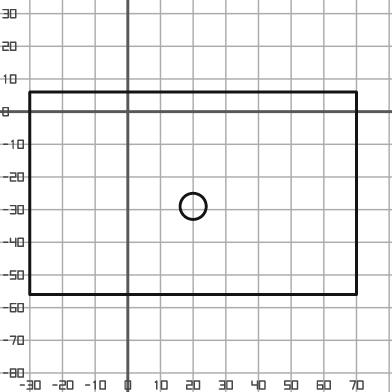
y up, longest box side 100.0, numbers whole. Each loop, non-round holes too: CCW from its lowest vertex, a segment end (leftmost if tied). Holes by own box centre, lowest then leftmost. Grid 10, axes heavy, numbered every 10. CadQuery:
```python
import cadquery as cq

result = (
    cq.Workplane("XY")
    .moveTo(-30.0, -56.0)
    .lineTo(70.0, -56.0)
    .lineTo(70.0, 6.0)
    .lineTo(-30.0, 6.0)
    .close()
    .moveTo(20.0, -29.0)
    .circle(4.0)
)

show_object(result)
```